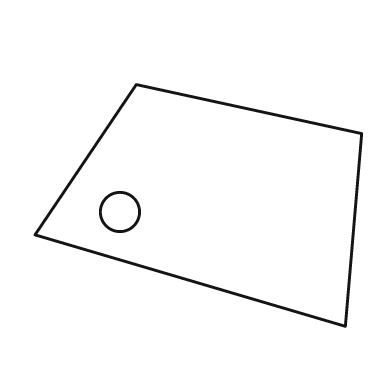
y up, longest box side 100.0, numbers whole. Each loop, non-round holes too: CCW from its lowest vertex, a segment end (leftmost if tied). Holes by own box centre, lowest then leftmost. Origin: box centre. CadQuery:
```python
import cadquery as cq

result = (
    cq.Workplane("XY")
    .moveTo(45.0, -37.0)
    .lineTo(50.0, 22.0)
    .lineTo(-19.0, 37.0)
    .lineTo(-50.0, -9.0)
    .close()
    .moveTo(-24.0, -2.0)
    .circle(6.0)
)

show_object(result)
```